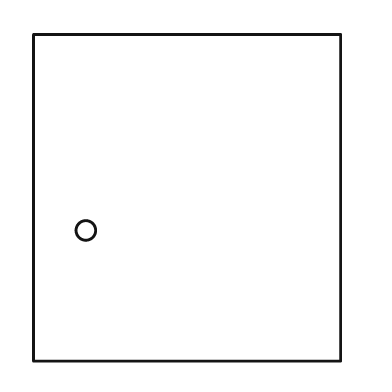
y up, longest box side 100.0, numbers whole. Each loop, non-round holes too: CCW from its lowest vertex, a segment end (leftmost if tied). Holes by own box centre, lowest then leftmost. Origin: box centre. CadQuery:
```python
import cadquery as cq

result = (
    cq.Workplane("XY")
    .moveTo(-47.0, -50.0)
    .lineTo(47.0, -50.0)
    .lineTo(47.0, 50.0)
    .lineTo(-47.0, 50.0)
    .close()
    .moveTo(-31.0, -10.0)
    .circle(3.0)
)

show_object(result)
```